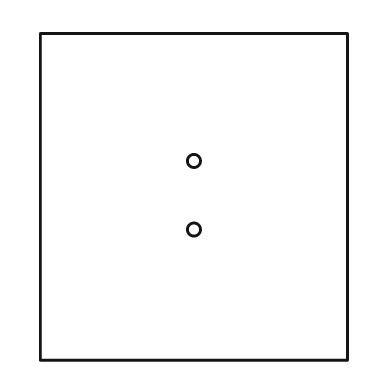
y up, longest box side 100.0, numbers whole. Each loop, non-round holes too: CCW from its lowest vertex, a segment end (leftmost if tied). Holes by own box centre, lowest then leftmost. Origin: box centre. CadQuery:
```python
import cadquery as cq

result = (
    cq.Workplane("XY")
    .moveTo(-47.0, -50.0)
    .lineTo(47.0, -50.0)
    .lineTo(47.0, 50.0)
    .lineTo(-47.0, 50.0)
    .close()
    .moveTo(0.0, -10.0)
    .circle(2.0)
    .moveTo(0.0, 11.0)
    .circle(2.0)
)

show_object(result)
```